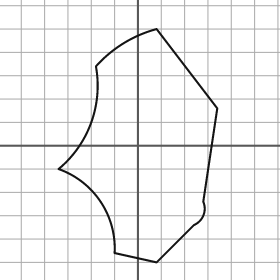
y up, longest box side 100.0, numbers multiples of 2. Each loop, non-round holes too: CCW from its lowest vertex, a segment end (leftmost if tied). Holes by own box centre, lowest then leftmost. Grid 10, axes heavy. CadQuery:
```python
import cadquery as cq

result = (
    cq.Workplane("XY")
    .moveTo(8.0, -50.0)
    .lineTo(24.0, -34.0)
    .threePointArc((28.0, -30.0), (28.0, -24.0))
    .lineTo(34.0, 16.0)
    .lineTo(8.0, 50.0)
    .threePointArc((-6.0, 44.0), (-18.0, 34.0))
    .threePointArc((-20.0, 10.0), (-34.0, -10.0))
    .threePointArc((-16.0, -24.0), (-10.0, -46.0))
    .close()
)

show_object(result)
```